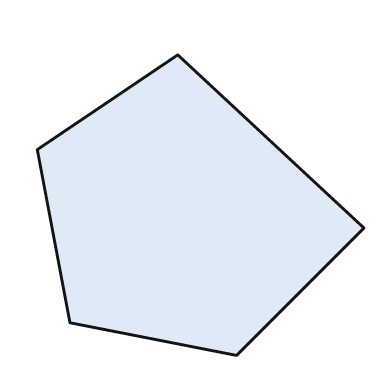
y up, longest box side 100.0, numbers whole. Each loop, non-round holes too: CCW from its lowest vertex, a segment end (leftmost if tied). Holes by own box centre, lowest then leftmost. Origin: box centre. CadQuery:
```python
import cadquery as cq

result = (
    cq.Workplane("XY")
    .moveTo(11.0, -46.0)
    .lineTo(50.0, -7.0)
    .lineTo(-7.0, 46.0)
    .lineTo(-50.0, 17.0)
    .lineTo(-40.0, -36.0)
    .close()
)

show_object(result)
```